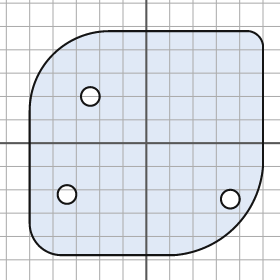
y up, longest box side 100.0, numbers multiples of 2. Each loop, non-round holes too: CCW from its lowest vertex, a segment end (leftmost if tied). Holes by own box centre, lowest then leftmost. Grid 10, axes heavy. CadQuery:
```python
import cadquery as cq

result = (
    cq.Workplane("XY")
    .moveTo(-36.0, -48.0)
    .lineTo(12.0, -48.0)
    .threePointArc((38.0, -36.0), (50.0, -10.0))
    .lineTo(50.0, 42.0)
    .threePointArc((48.0, 46.0), (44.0, 48.0))
    .lineTo(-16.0, 48.0)
    .threePointArc((-40.0, 38.0), (-50.0, 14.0))
    .lineTo(-50.0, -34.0)
    .threePointArc((-46.0, -44.0), (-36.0, -48.0))
    .close()
    .moveTo(36.0, -24.0)
    .circle(4.0)
    .moveTo(-34.0, -22.0)
    .circle(4.0)
    .moveTo(-24.0, 20.0)
    .circle(4.0)
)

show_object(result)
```